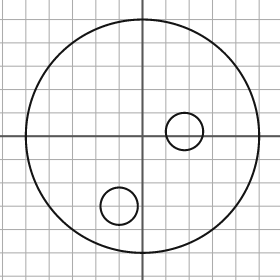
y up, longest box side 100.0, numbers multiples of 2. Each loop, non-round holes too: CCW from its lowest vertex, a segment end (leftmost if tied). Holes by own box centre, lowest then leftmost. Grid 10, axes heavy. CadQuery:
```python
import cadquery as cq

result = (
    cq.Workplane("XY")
    .moveTo(0.0, 0.0)
    .circle(50.0)
    .moveTo(-10.0, -30.0)
    .circle(8.0)
    .moveTo(18.0, 2.0)
    .circle(8.0)
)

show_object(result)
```